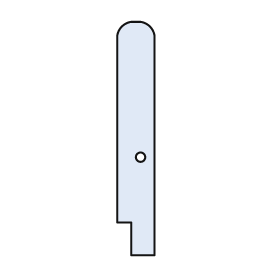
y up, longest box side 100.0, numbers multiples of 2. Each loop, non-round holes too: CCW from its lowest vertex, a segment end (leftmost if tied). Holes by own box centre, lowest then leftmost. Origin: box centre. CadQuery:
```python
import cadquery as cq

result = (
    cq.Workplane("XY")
    .moveTo(-2.0, -50.0)
    .lineTo(8.0, -50.0)
    .lineTo(8.0, 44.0)
    .threePointArc((6.0, 48.0), (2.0, 50.0))
    .lineTo(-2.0, 50.0)
    .threePointArc((-6.0, 48.0), (-8.0, 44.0))
    .lineTo(-8.0, -36.0)
    .lineTo(-2.0, -36.0)
    .close()
    .moveTo(2.0, -8.0)
    .circle(2.0)
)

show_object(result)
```